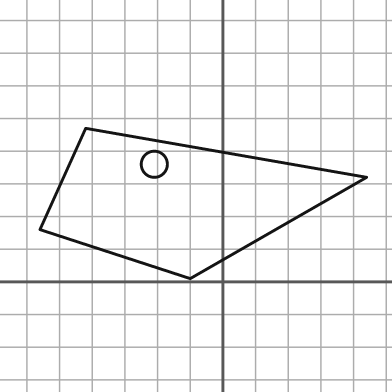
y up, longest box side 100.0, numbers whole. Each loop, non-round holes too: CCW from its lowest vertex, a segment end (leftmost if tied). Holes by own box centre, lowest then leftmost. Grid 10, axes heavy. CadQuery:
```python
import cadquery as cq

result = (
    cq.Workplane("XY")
    .moveTo(-10.0, 1.0)
    .lineTo(44.0, 32.0)
    .lineTo(-42.0, 47.0)
    .lineTo(-56.0, 16.0)
    .close()
    .moveTo(-21.0, 36.0)
    .circle(4.0)
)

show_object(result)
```